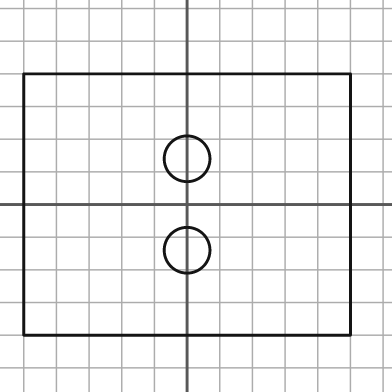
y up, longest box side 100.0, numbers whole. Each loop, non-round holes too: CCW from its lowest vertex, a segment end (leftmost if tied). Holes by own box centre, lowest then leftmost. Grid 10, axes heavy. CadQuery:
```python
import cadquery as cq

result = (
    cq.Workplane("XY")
    .moveTo(-50.0, -40.0)
    .lineTo(50.0, -40.0)
    .lineTo(50.0, 40.0)
    .lineTo(-50.0, 40.0)
    .close()
    .moveTo(0.0, -14.0)
    .circle(7.0)
    .moveTo(0.0, 14.0)
    .circle(7.0)
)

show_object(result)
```